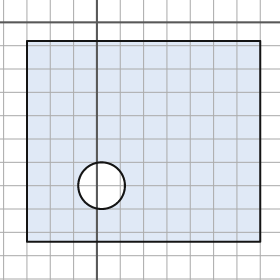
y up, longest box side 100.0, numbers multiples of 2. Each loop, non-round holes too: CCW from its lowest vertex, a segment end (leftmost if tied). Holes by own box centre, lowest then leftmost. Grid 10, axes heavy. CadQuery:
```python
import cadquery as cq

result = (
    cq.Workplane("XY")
    .moveTo(-30.0, -94.0)
    .lineTo(70.0, -94.0)
    .lineTo(70.0, -8.0)
    .lineTo(-30.0, -8.0)
    .close()
    .moveTo(2.0, -70.0)
    .circle(10.0)
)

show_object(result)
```